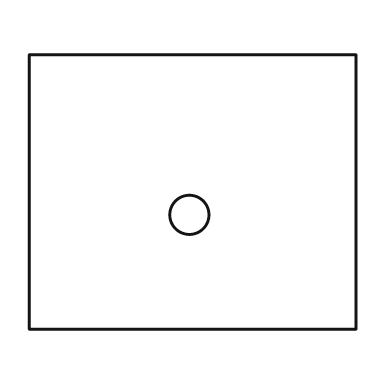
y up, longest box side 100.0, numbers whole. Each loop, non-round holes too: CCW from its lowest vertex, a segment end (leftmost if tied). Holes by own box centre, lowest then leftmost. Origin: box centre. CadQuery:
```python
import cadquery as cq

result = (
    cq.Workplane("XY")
    .moveTo(-50.0, -42.0)
    .lineTo(50.0, -42.0)
    .lineTo(50.0, 42.0)
    .lineTo(-50.0, 42.0)
    .close()
    .moveTo(-1.0, -7.0)
    .circle(6.0)
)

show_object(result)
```